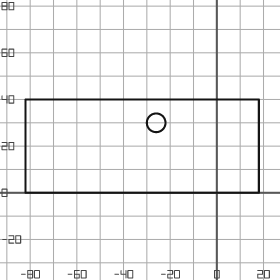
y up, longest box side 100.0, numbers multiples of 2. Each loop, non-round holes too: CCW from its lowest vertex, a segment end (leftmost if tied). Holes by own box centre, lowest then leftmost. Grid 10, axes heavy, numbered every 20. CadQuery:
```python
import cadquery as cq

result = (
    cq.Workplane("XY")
    .moveTo(-82.0, 0.0)
    .lineTo(18.0, 0.0)
    .lineTo(18.0, 40.0)
    .lineTo(-82.0, 40.0)
    .close()
    .moveTo(-26.0, 30.0)
    .circle(4.0)
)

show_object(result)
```